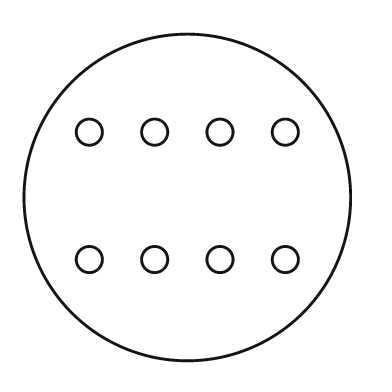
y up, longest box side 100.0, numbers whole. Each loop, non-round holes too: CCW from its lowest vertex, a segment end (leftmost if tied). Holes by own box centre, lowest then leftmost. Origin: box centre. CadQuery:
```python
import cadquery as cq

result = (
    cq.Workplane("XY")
    .moveTo(0.0, 0.0)
    .circle(50.0)
    .moveTo(-30.0, -19.0)
    .circle(4.0)
    .moveTo(-10.0, -19.0)
    .circle(4.0)
    .moveTo(10.0, -19.0)
    .circle(4.0)
    .moveTo(30.0, -19.0)
    .circle(4.0)
    .moveTo(-30.0, 20.0)
    .circle(4.0)
    .moveTo(-10.0, 20.0)
    .circle(4.0)
    .moveTo(10.0, 20.0)
    .circle(4.0)
    .moveTo(30.0, 20.0)
    .circle(4.0)
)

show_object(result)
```